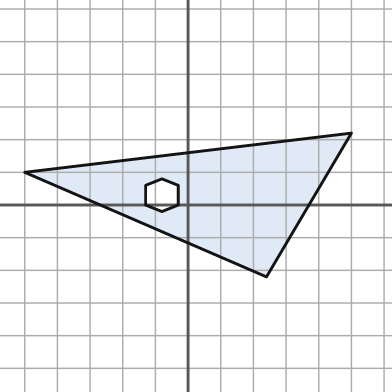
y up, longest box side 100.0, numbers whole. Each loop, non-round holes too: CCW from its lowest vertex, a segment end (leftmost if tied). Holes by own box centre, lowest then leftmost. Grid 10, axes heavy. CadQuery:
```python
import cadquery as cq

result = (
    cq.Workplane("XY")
    .moveTo(24.0, -22.0)
    .lineTo(50.0, 22.0)
    .lineTo(-50.0, 10.0)
    .close()
    .moveTo(-8.0, -2.0)
    .lineTo(-3.0, 0.0)
    .lineTo(-3.0, 6.0)
    .lineTo(-8.0, 8.0)
    .lineTo(-13.0, 6.0)
    .lineTo(-13.0, 0.0)
    .close()
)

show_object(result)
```